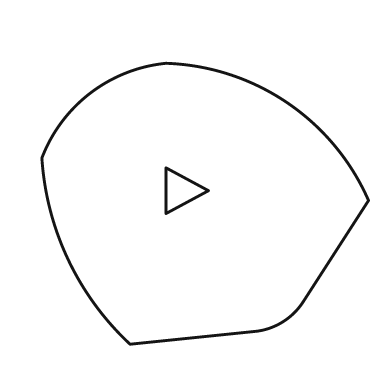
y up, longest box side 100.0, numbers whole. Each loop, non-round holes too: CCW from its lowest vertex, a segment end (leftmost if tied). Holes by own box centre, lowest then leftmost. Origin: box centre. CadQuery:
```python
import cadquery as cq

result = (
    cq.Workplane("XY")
    .moveTo(-23.0, -43.0)
    .lineTo(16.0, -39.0)
    .threePointArc((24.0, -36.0), (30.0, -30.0))
    .lineTo(50.0, 1.0)
    .threePointArc((25.0, 31.0), (-12.0, 43.0))
    .threePointArc((-35.0, 34.0), (-50.0, 14.0))
    .threePointArc((-42.0, -17.0), (-23.0, -43.0))
    .close()
    .moveTo(-12.0, -3.0)
    .lineTo(1.0, 4.0)
    .lineTo(-12.0, 11.0)
    .close()
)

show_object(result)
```